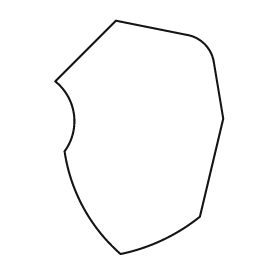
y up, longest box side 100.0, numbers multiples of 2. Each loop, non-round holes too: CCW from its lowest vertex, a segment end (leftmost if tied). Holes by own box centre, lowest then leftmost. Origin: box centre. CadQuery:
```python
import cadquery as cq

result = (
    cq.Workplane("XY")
    .moveTo(-8.0, -50.0)
    .threePointArc((10.0, -44.0), (26.0, -34.0))
    .lineTo(36.0, 8.0)
    .lineTo(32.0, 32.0)
    .threePointArc((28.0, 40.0), (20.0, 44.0))
    .lineTo(-10.0, 50.0)
    .lineTo(-36.0, 24.0)
    .threePointArc((-28.0, 10.0), (-32.0, -6.0))
    .threePointArc((-24.0, -30.0), (-8.0, -50.0))
    .close()
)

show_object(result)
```